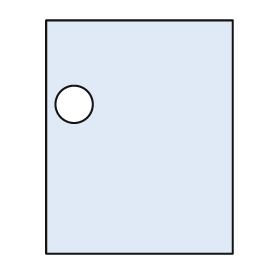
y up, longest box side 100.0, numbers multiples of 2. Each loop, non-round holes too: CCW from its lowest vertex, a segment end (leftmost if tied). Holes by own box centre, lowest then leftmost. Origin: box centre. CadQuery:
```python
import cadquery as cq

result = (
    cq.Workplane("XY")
    .moveTo(-40.0, -50.0)
    .lineTo(40.0, -50.0)
    .lineTo(40.0, 50.0)
    .lineTo(-40.0, 50.0)
    .close()
    .moveTo(-28.0, 14.0)
    .circle(8.0)
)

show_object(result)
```